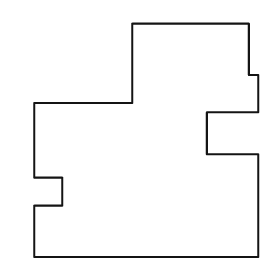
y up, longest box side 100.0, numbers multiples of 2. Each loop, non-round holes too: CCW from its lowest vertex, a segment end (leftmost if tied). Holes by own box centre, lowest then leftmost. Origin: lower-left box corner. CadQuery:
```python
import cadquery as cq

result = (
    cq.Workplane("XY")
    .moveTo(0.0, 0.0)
    .lineTo(96.0, 0.0)
    .lineTo(96.0, 44.0)
    .lineTo(74.0, 44.0)
    .lineTo(74.0, 62.0)
    .lineTo(96.0, 62.0)
    .lineTo(96.0, 78.0)
    .lineTo(92.0, 78.0)
    .lineTo(92.0, 100.0)
    .lineTo(42.0, 100.0)
    .lineTo(42.0, 66.0)
    .lineTo(0.0, 66.0)
    .lineTo(0.0, 34.0)
    .lineTo(12.0, 34.0)
    .lineTo(12.0, 22.0)
    .lineTo(0.0, 22.0)
    .close()
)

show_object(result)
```